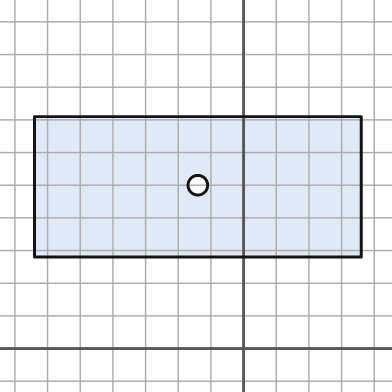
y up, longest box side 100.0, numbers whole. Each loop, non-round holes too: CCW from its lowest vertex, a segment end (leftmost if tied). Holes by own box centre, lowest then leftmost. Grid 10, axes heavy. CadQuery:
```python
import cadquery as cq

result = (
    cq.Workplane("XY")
    .moveTo(-64.0, 28.0)
    .lineTo(36.0, 28.0)
    .lineTo(36.0, 71.0)
    .lineTo(-64.0, 71.0)
    .close()
    .moveTo(-14.0, 50.0)
    .circle(3.0)
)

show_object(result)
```